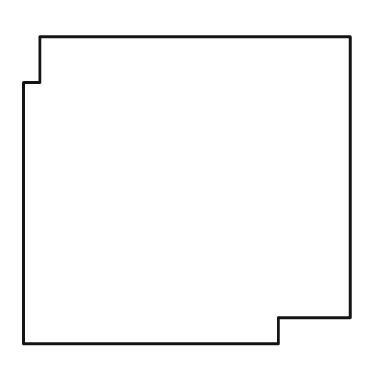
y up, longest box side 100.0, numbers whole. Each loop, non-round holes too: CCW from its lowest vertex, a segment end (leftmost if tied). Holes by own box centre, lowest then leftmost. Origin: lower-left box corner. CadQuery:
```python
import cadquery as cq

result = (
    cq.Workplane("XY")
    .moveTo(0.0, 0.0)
    .lineTo(78.0, 0.0)
    .lineTo(78.0, 8.0)
    .lineTo(100.0, 8.0)
    .lineTo(100.0, 94.0)
    .lineTo(5.0, 94.0)
    .lineTo(5.0, 80.0)
    .lineTo(0.0, 80.0)
    .close()
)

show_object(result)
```